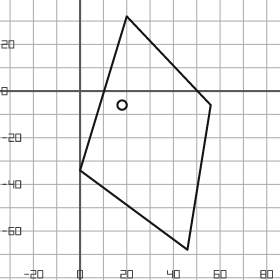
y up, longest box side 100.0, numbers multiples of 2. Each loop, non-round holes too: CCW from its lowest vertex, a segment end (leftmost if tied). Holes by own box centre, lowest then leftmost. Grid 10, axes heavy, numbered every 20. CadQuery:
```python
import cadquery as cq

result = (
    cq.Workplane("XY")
    .moveTo(46.0, -68.0)
    .lineTo(56.0, -6.0)
    .lineTo(20.0, 32.0)
    .lineTo(0.0, -34.0)
    .close()
    .moveTo(18.0, -6.0)
    .circle(2.0)
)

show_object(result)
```